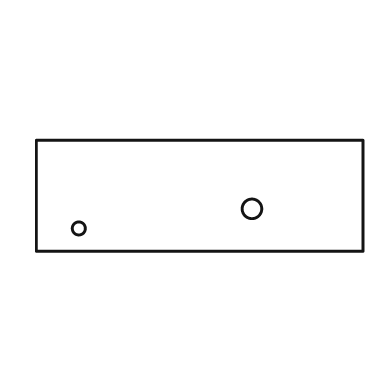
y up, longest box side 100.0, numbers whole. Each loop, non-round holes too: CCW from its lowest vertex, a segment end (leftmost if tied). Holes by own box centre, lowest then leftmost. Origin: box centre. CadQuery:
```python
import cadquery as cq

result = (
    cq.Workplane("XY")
    .moveTo(-50.0, -17.0)
    .lineTo(50.0, -17.0)
    .lineTo(50.0, 17.0)
    .lineTo(-50.0, 17.0)
    .close()
    .moveTo(-37.0, -10.0)
    .circle(2.0)
    .moveTo(16.0, -4.0)
    .circle(3.0)
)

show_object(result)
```